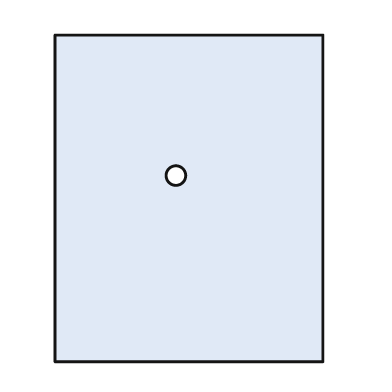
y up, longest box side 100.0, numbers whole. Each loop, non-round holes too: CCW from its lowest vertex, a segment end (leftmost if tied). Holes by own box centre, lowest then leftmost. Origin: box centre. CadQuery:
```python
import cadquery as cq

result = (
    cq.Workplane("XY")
    .moveTo(-41.0, -50.0)
    .lineTo(41.0, -50.0)
    .lineTo(41.0, 50.0)
    .lineTo(-41.0, 50.0)
    .close()
    .moveTo(-4.0, 7.0)
    .circle(3.0)
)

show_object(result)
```